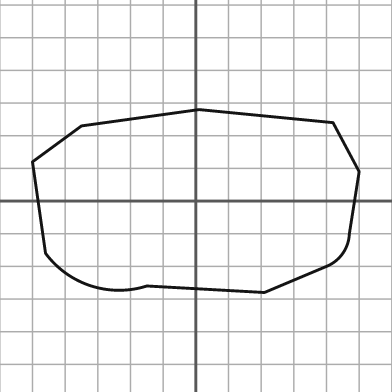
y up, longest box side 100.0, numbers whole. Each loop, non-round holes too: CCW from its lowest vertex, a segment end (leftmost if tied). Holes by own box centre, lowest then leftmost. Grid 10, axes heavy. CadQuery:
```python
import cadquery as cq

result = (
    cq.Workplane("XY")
    .moveTo(21.0, -28.0)
    .lineTo(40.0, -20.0)
    .threePointArc((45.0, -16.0), (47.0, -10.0))
    .lineTo(50.0, 9.0)
    .lineTo(42.0, 24.0)
    .lineTo(1.0, 28.0)
    .lineTo(-35.0, 23.0)
    .lineTo(-50.0, 12.0)
    .lineTo(-46.0, -16.0)
    .threePointArc((-32.0, -26.0), (-15.0, -26.0))
    .close()
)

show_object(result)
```